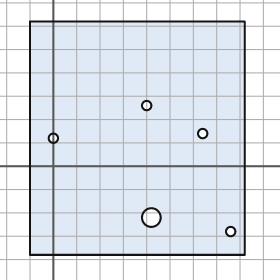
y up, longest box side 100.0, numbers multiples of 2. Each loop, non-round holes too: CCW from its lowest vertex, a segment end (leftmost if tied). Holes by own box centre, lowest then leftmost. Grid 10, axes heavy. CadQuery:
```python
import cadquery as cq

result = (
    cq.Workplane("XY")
    .moveTo(-10.0, -38.0)
    .lineTo(82.0, -38.0)
    .lineTo(82.0, 62.0)
    .lineTo(-10.0, 62.0)
    .close()
    .moveTo(76.0, -28.0)
    .circle(2.0)
    .moveTo(42.0, -22.0)
    .circle(4.0)
    .moveTo(0.0, 12.0)
    .circle(2.0)
    .moveTo(64.0, 14.0)
    .circle(2.0)
    .moveTo(40.0, 26.0)
    .circle(2.0)
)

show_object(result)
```